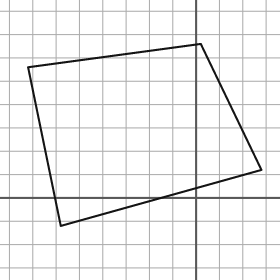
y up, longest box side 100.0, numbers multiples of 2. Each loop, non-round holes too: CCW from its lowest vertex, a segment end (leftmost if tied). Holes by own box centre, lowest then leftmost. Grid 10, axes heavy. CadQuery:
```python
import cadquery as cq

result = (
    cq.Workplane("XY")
    .moveTo(-58.0, -12.0)
    .lineTo(28.0, 12.0)
    .lineTo(2.0, 66.0)
    .lineTo(-72.0, 56.0)
    .close()
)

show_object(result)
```